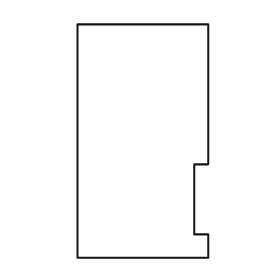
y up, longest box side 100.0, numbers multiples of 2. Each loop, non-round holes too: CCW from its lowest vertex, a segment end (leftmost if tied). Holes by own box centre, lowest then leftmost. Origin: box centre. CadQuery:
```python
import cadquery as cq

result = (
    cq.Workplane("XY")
    .moveTo(-28.0, -50.0)
    .lineTo(28.0, -50.0)
    .lineTo(28.0, -40.0)
    .lineTo(22.0, -40.0)
    .lineTo(22.0, -10.0)
    .lineTo(28.0, -10.0)
    .lineTo(28.0, 50.0)
    .lineTo(-28.0, 50.0)
    .close()
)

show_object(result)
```